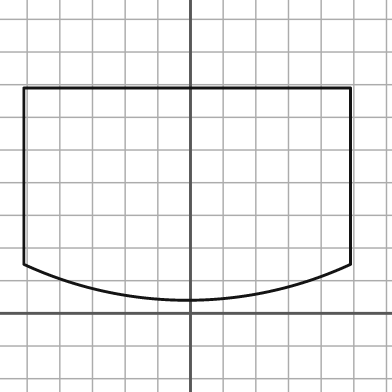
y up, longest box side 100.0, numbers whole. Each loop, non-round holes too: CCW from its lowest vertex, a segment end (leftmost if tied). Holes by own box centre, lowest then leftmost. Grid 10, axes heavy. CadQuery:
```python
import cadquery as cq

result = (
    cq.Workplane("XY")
    .moveTo(-51.0, 15.0)
    .threePointArc((-1.0, 4.0), (49.0, 15.0))
    .lineTo(49.0, 69.0)
    .lineTo(-51.0, 69.0)
    .close()
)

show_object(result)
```